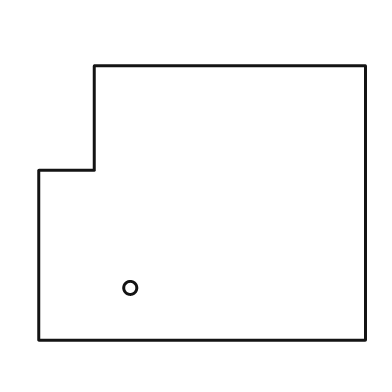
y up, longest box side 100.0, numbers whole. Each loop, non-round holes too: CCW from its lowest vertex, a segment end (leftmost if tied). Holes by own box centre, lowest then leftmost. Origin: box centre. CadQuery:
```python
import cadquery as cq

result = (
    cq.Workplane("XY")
    .moveTo(-50.0, -42.0)
    .lineTo(50.0, -42.0)
    .lineTo(50.0, 42.0)
    .lineTo(-33.0, 42.0)
    .lineTo(-33.0, 10.0)
    .lineTo(-50.0, 10.0)
    .close()
    .moveTo(-22.0, -26.0)
    .circle(2.0)
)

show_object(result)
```